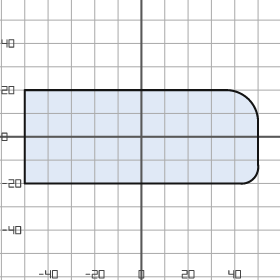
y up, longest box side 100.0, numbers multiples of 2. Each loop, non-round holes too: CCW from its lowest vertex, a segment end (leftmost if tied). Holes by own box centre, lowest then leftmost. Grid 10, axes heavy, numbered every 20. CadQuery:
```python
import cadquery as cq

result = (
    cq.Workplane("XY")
    .moveTo(-50.0, -20.0)
    .lineTo(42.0, -20.0)
    .threePointArc((48.0, -18.0), (50.0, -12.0))
    .lineTo(50.0, 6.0)
    .threePointArc((46.0, 16.0), (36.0, 20.0))
    .lineTo(-50.0, 20.0)
    .close()
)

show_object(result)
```